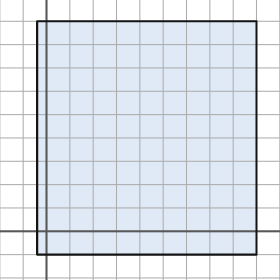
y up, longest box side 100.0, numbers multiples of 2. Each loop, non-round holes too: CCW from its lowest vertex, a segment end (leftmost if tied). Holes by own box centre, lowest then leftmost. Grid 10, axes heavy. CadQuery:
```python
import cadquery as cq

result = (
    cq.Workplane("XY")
    .moveTo(-4.0, -10.0)
    .lineTo(90.0, -10.0)
    .lineTo(90.0, 90.0)
    .lineTo(-4.0, 90.0)
    .close()
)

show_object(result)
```